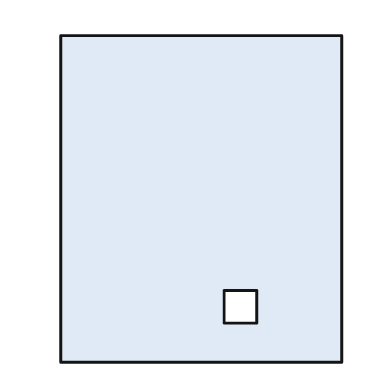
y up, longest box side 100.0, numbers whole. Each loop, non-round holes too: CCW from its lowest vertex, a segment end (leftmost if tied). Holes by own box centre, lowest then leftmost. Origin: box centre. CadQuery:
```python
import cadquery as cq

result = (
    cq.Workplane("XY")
    .moveTo(-43.0, -50.0)
    .lineTo(43.0, -50.0)
    .lineTo(43.0, 50.0)
    .lineTo(-43.0, 50.0)
    .close()
    .moveTo(7.0, -38.0)
    .lineTo(17.0, -38.0)
    .lineTo(17.0, -28.0)
    .lineTo(7.0, -28.0)
    .close()
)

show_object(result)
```